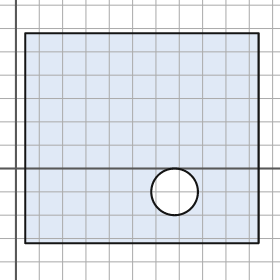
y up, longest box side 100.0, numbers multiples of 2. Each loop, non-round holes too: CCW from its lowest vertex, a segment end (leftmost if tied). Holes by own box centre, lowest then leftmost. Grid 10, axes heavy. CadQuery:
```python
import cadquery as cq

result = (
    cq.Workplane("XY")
    .moveTo(4.0, -32.0)
    .lineTo(104.0, -32.0)
    .lineTo(104.0, 58.0)
    .lineTo(4.0, 58.0)
    .close()
    .moveTo(68.0, -10.0)
    .circle(10.0)
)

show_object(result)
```